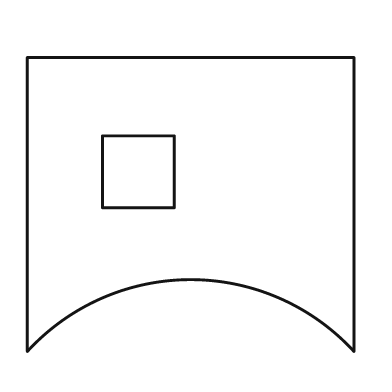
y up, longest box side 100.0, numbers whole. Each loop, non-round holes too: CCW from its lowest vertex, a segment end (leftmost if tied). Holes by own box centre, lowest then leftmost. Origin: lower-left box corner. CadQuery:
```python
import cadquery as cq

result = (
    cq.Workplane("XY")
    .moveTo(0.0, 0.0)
    .threePointArc((50.0, 22.0), (100.0, 0.0))
    .lineTo(100.0, 90.0)
    .lineTo(0.0, 90.0)
    .close()
    .moveTo(23.0, 44.0)
    .lineTo(45.0, 44.0)
    .lineTo(45.0, 66.0)
    .lineTo(23.0, 66.0)
    .close()
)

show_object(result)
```